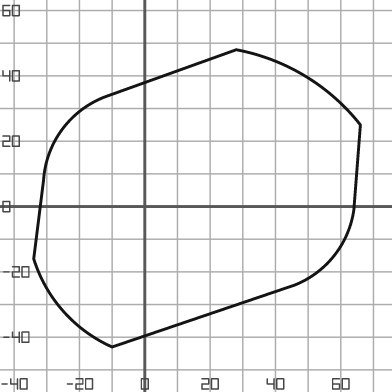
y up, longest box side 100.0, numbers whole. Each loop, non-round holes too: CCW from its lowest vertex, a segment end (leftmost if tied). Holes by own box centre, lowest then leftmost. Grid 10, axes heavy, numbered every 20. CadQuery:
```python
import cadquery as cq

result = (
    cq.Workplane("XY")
    .moveTo(-10.0, -43.0)
    .lineTo(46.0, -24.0)
    .threePointArc((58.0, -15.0), (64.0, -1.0))
    .lineTo(66.0, 25.0)
    .threePointArc((49.0, 40.0), (28.0, 48.0))
    .lineTo(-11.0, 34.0)
    .threePointArc((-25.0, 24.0), (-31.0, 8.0))
    .lineTo(-34.0, -16.0)
    .threePointArc((-25.0, -32.0), (-10.0, -43.0))
    .close()
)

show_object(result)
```